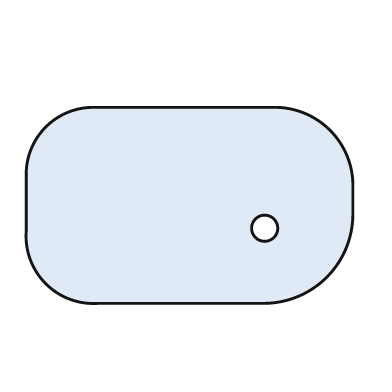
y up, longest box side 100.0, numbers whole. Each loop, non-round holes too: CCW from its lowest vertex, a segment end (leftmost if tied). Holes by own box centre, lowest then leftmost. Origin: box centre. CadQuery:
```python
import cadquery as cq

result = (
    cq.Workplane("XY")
    .moveTo(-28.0, -30.0)
    .lineTo(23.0, -30.0)
    .threePointArc((42.0, -22.0), (50.0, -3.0))
    .lineTo(50.0, 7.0)
    .threePointArc((43.0, 23.0), (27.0, 30.0))
    .lineTo(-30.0, 30.0)
    .threePointArc((-44.0, 24.0), (-50.0, 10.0))
    .lineTo(-50.0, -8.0)
    .threePointArc((-44.0, -24.0), (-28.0, -30.0))
    .close()
    .moveTo(23.0, -7.0)
    .circle(4.0)
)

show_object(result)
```